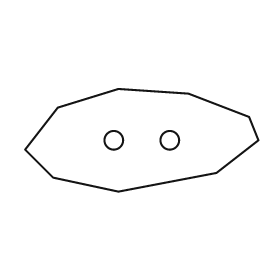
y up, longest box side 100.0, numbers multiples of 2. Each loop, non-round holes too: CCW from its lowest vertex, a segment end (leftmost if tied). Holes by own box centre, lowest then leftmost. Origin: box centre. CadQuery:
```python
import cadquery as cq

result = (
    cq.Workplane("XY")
    .moveTo(-10.0, -22.0)
    .lineTo(32.0, -14.0)
    .lineTo(50.0, 0.0)
    .lineTo(46.0, 10.0)
    .lineTo(20.0, 20.0)
    .lineTo(-10.0, 22.0)
    .lineTo(-36.0, 14.0)
    .lineTo(-50.0, -4.0)
    .lineTo(-38.0, -16.0)
    .close()
    .moveTo(-12.0, 0.0)
    .circle(4.0)
    .moveTo(12.0, 0.0)
    .circle(4.0)
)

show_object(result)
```